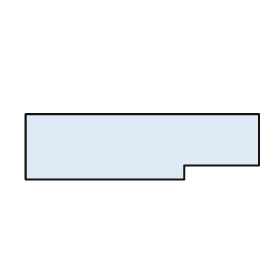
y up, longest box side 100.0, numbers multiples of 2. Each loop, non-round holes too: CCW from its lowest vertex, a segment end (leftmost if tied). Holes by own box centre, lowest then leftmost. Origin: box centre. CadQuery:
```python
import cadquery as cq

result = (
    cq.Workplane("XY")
    .moveTo(-50.0, -14.0)
    .lineTo(18.0, -14.0)
    .lineTo(18.0, -8.0)
    .lineTo(50.0, -8.0)
    .lineTo(50.0, 14.0)
    .lineTo(-50.0, 14.0)
    .close()
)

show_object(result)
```